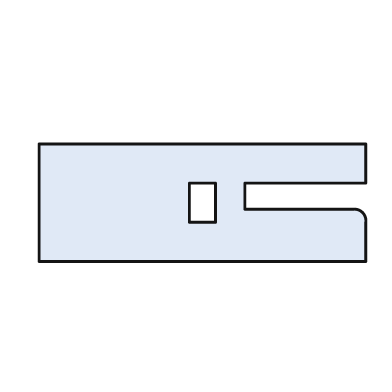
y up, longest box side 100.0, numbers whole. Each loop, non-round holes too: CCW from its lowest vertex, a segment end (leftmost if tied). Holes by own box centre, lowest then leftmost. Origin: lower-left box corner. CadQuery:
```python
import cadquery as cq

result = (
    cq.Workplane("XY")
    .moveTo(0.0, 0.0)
    .lineTo(100.0, 0.0)
    .lineTo(100.0, 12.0)
    .threePointArc((99.0, 15.0), (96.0, 16.0))
    .lineTo(63.0, 16.0)
    .lineTo(63.0, 24.0)
    .lineTo(100.0, 24.0)
    .lineTo(100.0, 36.0)
    .lineTo(0.0, 36.0)
    .close()
    .moveTo(46.0, 12.0)
    .lineTo(54.0, 12.0)
    .lineTo(54.0, 24.0)
    .lineTo(46.0, 24.0)
    .close()
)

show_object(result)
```